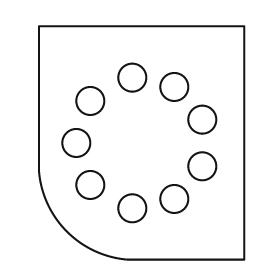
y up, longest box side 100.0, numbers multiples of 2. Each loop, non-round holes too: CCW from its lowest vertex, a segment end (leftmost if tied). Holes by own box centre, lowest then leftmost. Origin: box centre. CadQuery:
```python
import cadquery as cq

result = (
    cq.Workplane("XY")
    .moveTo(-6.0, -50.0)
    .lineTo(44.0, -50.0)
    .lineTo(44.0, 50.0)
    .lineTo(-44.0, 50.0)
    .lineTo(-44.0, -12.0)
    .threePointArc((-32.0, -38.0), (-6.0, -50.0))
    .close()
    .moveTo(-4.0, -28.0)
    .circle(6.0)
    .moveTo(14.0, -24.0)
    .circle(6.0)
    .moveTo(-22.0, -18.0)
    .circle(6.0)
    .moveTo(26.0, -10.0)
    .circle(6.0)
    .moveTo(-28.0, 0.0)
    .circle(6.0)
    .moveTo(26.0, 10.0)
    .circle(6.0)
    .moveTo(-22.0, 18.0)
    .circle(6.0)
    .moveTo(14.0, 24.0)
    .circle(6.0)
    .moveTo(-4.0, 28.0)
    .circle(6.0)
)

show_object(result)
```